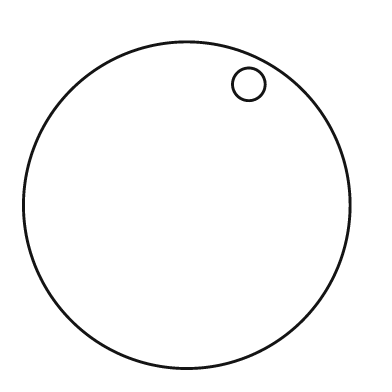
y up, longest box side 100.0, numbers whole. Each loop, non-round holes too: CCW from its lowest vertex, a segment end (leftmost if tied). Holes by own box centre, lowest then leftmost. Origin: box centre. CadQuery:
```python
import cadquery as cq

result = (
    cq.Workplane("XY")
    .moveTo(0.0, 0.0)
    .circle(50.0)
    .moveTo(19.0, 37.0)
    .circle(5.0)
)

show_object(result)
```